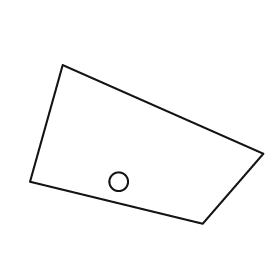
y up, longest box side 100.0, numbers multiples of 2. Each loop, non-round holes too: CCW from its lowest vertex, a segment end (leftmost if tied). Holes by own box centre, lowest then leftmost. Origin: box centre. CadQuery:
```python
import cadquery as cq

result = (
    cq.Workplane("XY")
    .moveTo(24.0, -34.0)
    .lineTo(50.0, -4.0)
    .lineTo(-36.0, 34.0)
    .lineTo(-50.0, -16.0)
    .close()
    .moveTo(-12.0, -16.0)
    .circle(4.0)
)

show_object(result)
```